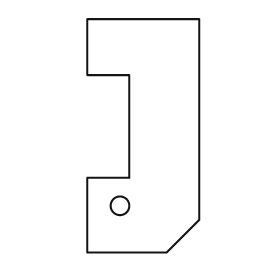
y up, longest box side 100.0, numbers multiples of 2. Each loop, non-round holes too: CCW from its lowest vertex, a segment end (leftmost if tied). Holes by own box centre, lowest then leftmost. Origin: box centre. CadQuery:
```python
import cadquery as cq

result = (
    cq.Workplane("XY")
    .moveTo(-24.0, -50.0)
    .lineTo(10.0, -50.0)
    .lineTo(24.0, -36.0)
    .lineTo(24.0, 50.0)
    .lineTo(-24.0, 50.0)
    .lineTo(-24.0, 26.0)
    .lineTo(-6.0, 26.0)
    .lineTo(-6.0, -18.0)
    .lineTo(-24.0, -18.0)
    .close()
    .moveTo(-10.0, -30.0)
    .circle(4.0)
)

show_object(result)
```